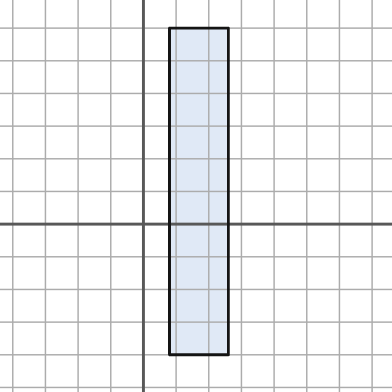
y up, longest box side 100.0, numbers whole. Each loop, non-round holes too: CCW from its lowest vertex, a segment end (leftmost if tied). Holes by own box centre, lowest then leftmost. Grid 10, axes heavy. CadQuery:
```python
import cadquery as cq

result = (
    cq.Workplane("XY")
    .moveTo(8.0, -40.0)
    .lineTo(26.0, -40.0)
    .lineTo(26.0, 60.0)
    .lineTo(8.0, 60.0)
    .close()
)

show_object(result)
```